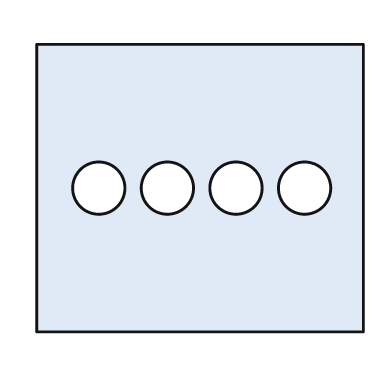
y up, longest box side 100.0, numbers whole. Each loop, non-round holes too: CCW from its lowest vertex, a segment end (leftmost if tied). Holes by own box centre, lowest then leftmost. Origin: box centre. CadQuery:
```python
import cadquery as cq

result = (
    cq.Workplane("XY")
    .moveTo(-50.0, -44.0)
    .lineTo(50.0, -44.0)
    .lineTo(50.0, 44.0)
    .lineTo(-50.0, 44.0)
    .close()
    .moveTo(-31.0, 0.0)
    .circle(8.0)
    .moveTo(-10.0, 0.0)
    .circle(8.0)
    .moveTo(11.0, 0.0)
    .circle(8.0)
    .moveTo(32.0, 0.0)
    .circle(8.0)
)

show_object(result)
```